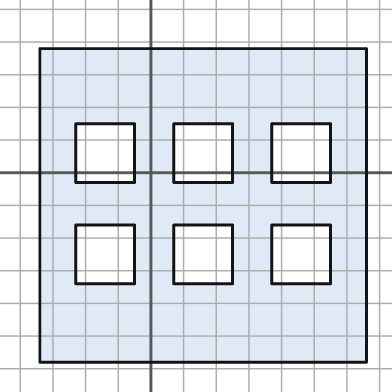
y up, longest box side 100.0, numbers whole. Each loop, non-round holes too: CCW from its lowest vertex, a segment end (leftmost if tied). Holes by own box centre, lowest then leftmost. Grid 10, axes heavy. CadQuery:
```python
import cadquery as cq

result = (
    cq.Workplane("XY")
    .moveTo(-34.0, -58.0)
    .lineTo(66.0, -58.0)
    .lineTo(66.0, 38.0)
    .lineTo(-34.0, 38.0)
    .close()
    .moveTo(-23.0, -34.0)
    .lineTo(-5.0, -34.0)
    .lineTo(-5.0, -16.0)
    .lineTo(-23.0, -16.0)
    .close()
    .moveTo(7.0, -34.0)
    .lineTo(25.0, -34.0)
    .lineTo(25.0, -16.0)
    .lineTo(7.0, -16.0)
    .close()
    .moveTo(37.0, -34.0)
    .lineTo(55.0, -34.0)
    .lineTo(55.0, -16.0)
    .lineTo(37.0, -16.0)
    .close()
    .moveTo(-23.0, -3.0)
    .lineTo(-5.0, -3.0)
    .lineTo(-5.0, 15.0)
    .lineTo(-23.0, 15.0)
    .close()
    .moveTo(7.0, -3.0)
    .lineTo(25.0, -3.0)
    .lineTo(25.0, 15.0)
    .lineTo(7.0, 15.0)
    .close()
    .moveTo(37.0, -3.0)
    .lineTo(55.0, -3.0)
    .lineTo(55.0, 15.0)
    .lineTo(37.0, 15.0)
    .close()
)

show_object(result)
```